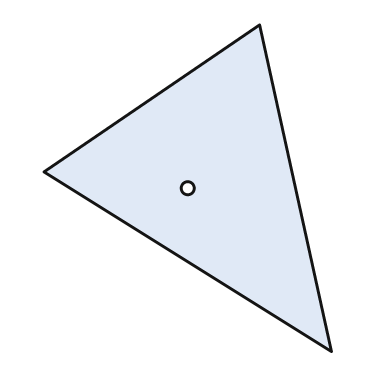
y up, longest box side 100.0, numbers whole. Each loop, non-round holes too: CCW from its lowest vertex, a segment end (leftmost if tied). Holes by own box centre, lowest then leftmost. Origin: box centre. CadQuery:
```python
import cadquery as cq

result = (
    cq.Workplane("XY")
    .moveTo(44.0, -50.0)
    .lineTo(22.0, 50.0)
    .lineTo(-44.0, 5.0)
    .close()
    .moveTo(0.0, 0.0)
    .circle(2.0)
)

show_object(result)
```